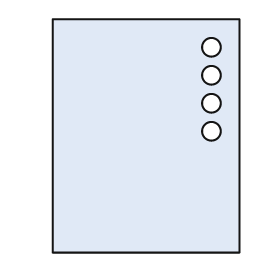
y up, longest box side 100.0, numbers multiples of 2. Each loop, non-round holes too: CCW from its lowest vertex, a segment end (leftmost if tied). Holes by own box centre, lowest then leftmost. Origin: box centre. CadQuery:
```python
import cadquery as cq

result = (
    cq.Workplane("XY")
    .moveTo(-40.0, -50.0)
    .lineTo(40.0, -50.0)
    .lineTo(40.0, 50.0)
    .lineTo(-40.0, 50.0)
    .close()
    .moveTo(28.0, 2.0)
    .circle(4.0)
    .moveTo(28.0, 14.0)
    .circle(4.0)
    .moveTo(28.0, 26.0)
    .circle(4.0)
    .moveTo(28.0, 38.0)
    .circle(4.0)
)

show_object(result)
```